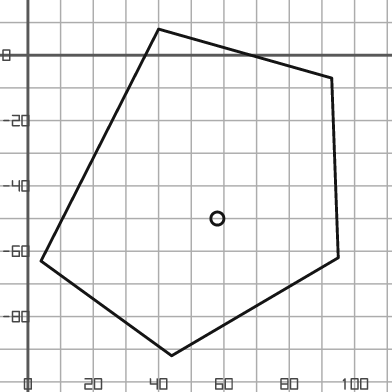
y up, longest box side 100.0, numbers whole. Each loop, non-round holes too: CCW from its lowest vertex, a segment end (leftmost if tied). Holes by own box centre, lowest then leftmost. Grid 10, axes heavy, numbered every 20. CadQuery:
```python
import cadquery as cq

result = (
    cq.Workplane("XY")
    .moveTo(44.0, -92.0)
    .lineTo(95.0, -62.0)
    .lineTo(93.0, -7.0)
    .lineTo(40.0, 8.0)
    .lineTo(4.0, -63.0)
    .close()
    .moveTo(58.0, -50.0)
    .circle(2.0)
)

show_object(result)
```